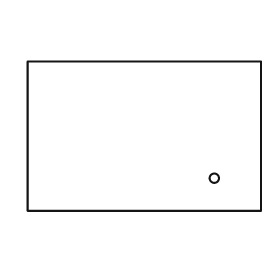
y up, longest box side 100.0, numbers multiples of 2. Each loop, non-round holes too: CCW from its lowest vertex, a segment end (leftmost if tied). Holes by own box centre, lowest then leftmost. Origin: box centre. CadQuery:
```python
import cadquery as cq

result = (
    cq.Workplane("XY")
    .moveTo(-50.0, -32.0)
    .lineTo(50.0, -32.0)
    .lineTo(50.0, 32.0)
    .lineTo(-50.0, 32.0)
    .close()
    .moveTo(30.0, -18.0)
    .circle(2.0)
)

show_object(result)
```